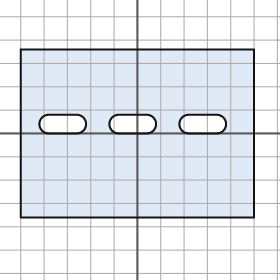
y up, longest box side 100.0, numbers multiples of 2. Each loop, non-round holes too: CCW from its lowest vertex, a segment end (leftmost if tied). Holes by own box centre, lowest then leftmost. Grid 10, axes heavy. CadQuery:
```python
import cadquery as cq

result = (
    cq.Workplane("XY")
    .moveTo(-50.0, -36.0)
    .lineTo(50.0, -36.0)
    .lineTo(50.0, 36.0)
    .lineTo(-50.0, 36.0)
    .close()
    .moveTo(-38.0, 0.0)
    .lineTo(-26.0, 0.0)
    .threePointArc((-22.0, 4.0), (-26.0, 8.0))
    .lineTo(-38.0, 8.0)
    .threePointArc((-42.0, 4.0), (-38.0, 0.0))
    .close()
    .moveTo(-8.0, 0.0)
    .lineTo(4.0, 0.0)
    .threePointArc((8.0, 4.0), (4.0, 8.0))
    .lineTo(-8.0, 8.0)
    .threePointArc((-12.0, 4.0), (-8.0, 0.0))
    .close()
    .moveTo(22.0, 0.0)
    .lineTo(34.0, 0.0)
    .threePointArc((38.0, 4.0), (34.0, 8.0))
    .lineTo(22.0, 8.0)
    .threePointArc((18.0, 4.0), (22.0, 0.0))
    .close()
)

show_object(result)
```